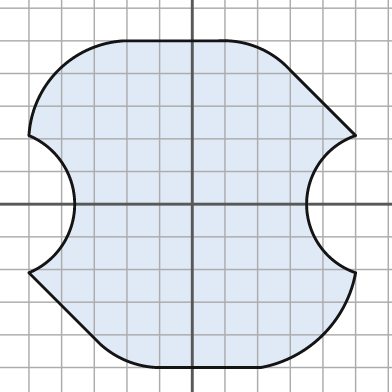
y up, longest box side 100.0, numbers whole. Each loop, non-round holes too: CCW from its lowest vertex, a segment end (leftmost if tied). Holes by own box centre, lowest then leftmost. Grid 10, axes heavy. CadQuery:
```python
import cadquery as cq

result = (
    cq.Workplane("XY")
    .moveTo(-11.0, -50.0)
    .lineTo(21.0, -50.0)
    .threePointArc((40.0, -40.0), (50.0, -21.0))
    .threePointArc((35.0, 0.0), (50.0, 21.0))
    .lineTo(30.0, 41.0)
    .threePointArc((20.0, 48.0), (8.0, 50.0))
    .lineTo(-21.0, 50.0)
    .threePointArc((-41.0, 41.0), (-50.0, 21.0))
    .threePointArc((-36.0, 0.0), (-50.0, -21.0))
    .lineTo(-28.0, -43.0)
    .threePointArc((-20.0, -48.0), (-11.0, -50.0))
    .close()
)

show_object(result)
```